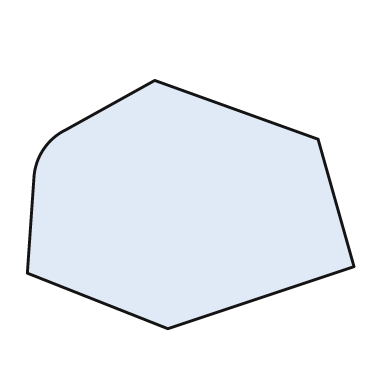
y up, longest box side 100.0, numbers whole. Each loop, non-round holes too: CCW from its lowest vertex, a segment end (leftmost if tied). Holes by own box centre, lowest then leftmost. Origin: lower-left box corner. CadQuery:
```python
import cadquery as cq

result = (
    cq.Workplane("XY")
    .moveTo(43.0, 0.0)
    .lineTo(100.0, 19.0)
    .lineTo(89.0, 58.0)
    .lineTo(39.0, 76.0)
    .lineTo(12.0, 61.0)
    .threePointArc((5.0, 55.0), (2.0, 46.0))
    .lineTo(0.0, 17.0)
    .close()
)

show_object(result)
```